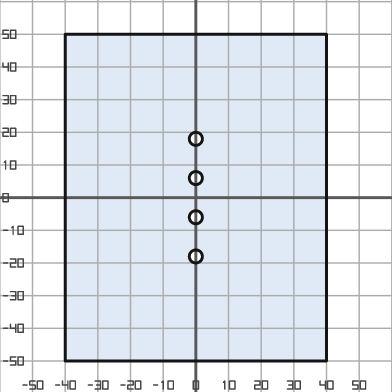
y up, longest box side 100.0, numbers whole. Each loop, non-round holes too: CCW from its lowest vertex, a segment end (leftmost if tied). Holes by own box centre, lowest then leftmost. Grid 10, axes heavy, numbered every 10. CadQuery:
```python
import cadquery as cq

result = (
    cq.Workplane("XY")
    .moveTo(-40.0, -50.0)
    .lineTo(40.0, -50.0)
    .lineTo(40.0, 50.0)
    .lineTo(-40.0, 50.0)
    .close()
    .moveTo(0.0, -18.0)
    .circle(2.0)
    .moveTo(0.0, -6.0)
    .circle(2.0)
    .moveTo(0.0, 6.0)
    .circle(2.0)
    .moveTo(0.0, 18.0)
    .circle(2.0)
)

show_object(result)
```